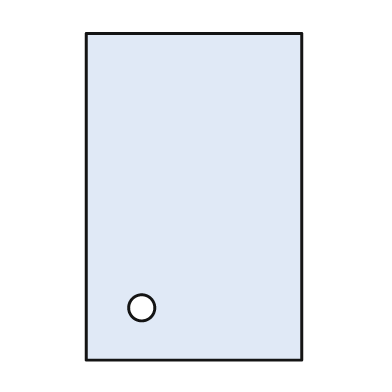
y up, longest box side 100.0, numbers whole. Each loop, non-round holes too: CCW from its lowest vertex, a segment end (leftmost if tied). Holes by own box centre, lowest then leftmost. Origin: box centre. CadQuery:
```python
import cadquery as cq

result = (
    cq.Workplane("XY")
    .moveTo(-33.0, -50.0)
    .lineTo(33.0, -50.0)
    .lineTo(33.0, 50.0)
    .lineTo(-33.0, 50.0)
    .close()
    .moveTo(-16.0, -34.0)
    .circle(4.0)
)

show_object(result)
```